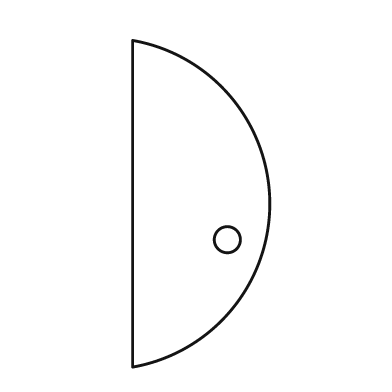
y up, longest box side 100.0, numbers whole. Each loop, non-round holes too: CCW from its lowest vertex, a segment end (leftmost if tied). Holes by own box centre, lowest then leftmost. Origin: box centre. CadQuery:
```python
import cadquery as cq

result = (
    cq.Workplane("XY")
    .moveTo(-21.0, -50.0)
    .threePointArc((21.0, 0.0), (-21.0, 50.0))
    .close()
    .moveTo(8.0, -11.0)
    .circle(4.0)
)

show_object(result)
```